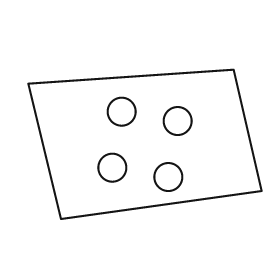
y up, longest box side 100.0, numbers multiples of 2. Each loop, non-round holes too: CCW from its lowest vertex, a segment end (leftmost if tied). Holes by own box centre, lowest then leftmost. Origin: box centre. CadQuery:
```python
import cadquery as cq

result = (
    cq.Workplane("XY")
    .moveTo(-36.0, -32.0)
    .lineTo(50.0, -20.0)
    .lineTo(38.0, 32.0)
    .lineTo(-50.0, 26.0)
    .close()
    .moveTo(10.0, -14.0)
    .circle(6.0)
    .moveTo(-14.0, -10.0)
    .circle(6.0)
    .moveTo(14.0, 10.0)
    .circle(6.0)
    .moveTo(-10.0, 14.0)
    .circle(6.0)
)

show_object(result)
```